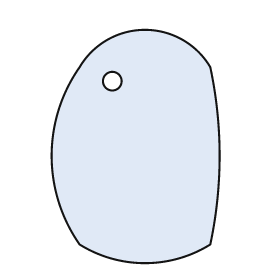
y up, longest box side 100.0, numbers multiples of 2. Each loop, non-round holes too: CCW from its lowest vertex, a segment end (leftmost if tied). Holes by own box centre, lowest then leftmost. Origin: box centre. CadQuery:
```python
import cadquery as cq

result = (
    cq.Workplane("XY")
    .moveTo(-24.0, -42.0)
    .threePointArc((4.0, -50.0), (32.0, -42.0))
    .threePointArc((36.0, -4.0), (32.0, 34.0))
    .threePointArc((4.0, 50.0), (-24.0, 34.0))
    .threePointArc((-36.0, -4.0), (-24.0, -42.0))
    .close()
    .moveTo(-10.0, 28.0)
    .circle(4.0)
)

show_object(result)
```